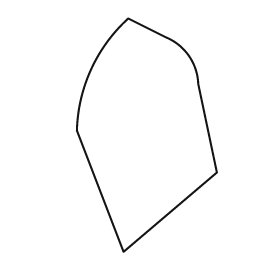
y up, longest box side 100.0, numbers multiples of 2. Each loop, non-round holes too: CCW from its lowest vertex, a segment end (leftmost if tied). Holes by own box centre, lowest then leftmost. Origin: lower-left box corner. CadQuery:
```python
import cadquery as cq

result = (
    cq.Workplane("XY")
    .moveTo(20.0, 0.0)
    .lineTo(60.0, 34.0)
    .lineTo(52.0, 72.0)
    .threePointArc((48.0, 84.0), (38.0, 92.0))
    .lineTo(22.0, 100.0)
    .threePointArc((6.0, 78.0), (0.0, 52.0))
    .close()
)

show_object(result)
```